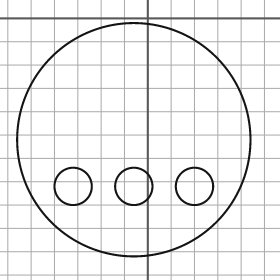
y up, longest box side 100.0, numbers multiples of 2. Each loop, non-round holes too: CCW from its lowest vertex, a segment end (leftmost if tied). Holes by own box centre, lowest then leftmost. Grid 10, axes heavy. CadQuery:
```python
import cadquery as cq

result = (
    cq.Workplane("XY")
    .moveTo(-6.0, -52.0)
    .circle(50.0)
    .moveTo(-32.0, -72.0)
    .circle(8.0)
    .moveTo(-6.0, -72.0)
    .circle(8.0)
    .moveTo(20.0, -72.0)
    .circle(8.0)
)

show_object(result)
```